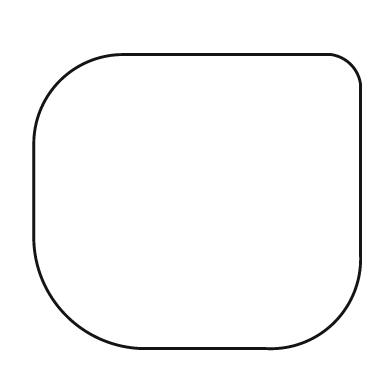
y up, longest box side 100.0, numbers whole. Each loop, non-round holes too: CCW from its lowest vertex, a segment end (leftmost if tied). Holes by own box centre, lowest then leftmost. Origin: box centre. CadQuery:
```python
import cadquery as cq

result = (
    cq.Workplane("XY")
    .moveTo(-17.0, -45.0)
    .lineTo(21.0, -45.0)
    .threePointArc((42.0, -37.0), (50.0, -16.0))
    .lineTo(50.0, 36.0)
    .threePointArc((47.0, 42.0), (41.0, 45.0))
    .lineTo(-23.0, 45.0)
    .threePointArc((-42.0, 37.0), (-50.0, 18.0))
    .lineTo(-50.0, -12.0)
    .threePointArc((-40.0, -35.0), (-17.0, -45.0))
    .close()
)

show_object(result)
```